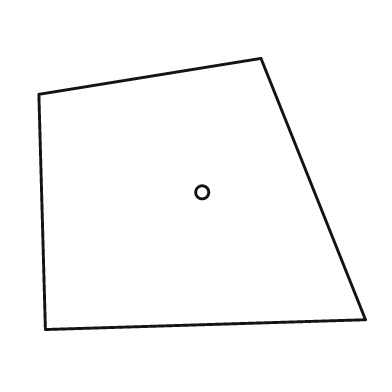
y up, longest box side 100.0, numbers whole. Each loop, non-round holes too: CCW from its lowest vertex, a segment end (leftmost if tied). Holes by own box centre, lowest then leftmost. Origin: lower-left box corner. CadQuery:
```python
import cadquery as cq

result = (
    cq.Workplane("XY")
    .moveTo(2.0, 0.0)
    .lineTo(100.0, 3.0)
    .lineTo(68.0, 83.0)
    .lineTo(0.0, 72.0)
    .close()
    .moveTo(50.0, 42.0)
    .circle(2.0)
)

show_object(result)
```